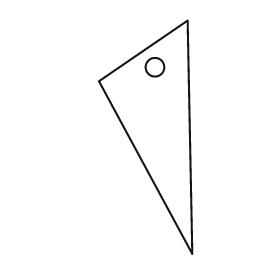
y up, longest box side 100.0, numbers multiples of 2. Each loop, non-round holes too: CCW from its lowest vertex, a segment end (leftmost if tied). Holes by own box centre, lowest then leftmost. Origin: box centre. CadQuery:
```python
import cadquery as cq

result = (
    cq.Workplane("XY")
    .moveTo(20.0, -50.0)
    .lineTo(18.0, 50.0)
    .lineTo(-20.0, 24.0)
    .close()
    .moveTo(4.0, 30.0)
    .circle(4.0)
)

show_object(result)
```